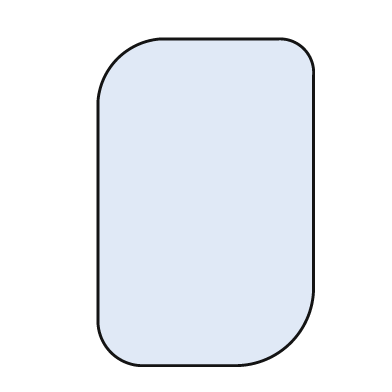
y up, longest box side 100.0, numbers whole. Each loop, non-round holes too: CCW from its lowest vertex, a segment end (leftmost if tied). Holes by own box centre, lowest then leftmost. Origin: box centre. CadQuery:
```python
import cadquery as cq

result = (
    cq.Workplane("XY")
    .moveTo(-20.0, -50.0)
    .lineTo(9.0, -50.0)
    .threePointArc((26.0, -43.0), (33.0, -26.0))
    .lineTo(33.0, 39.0)
    .threePointArc((30.0, 47.0), (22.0, 50.0))
    .lineTo(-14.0, 50.0)
    .threePointArc((-27.0, 44.0), (-33.0, 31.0))
    .lineTo(-33.0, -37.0)
    .threePointArc((-29.0, -46.0), (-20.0, -50.0))
    .close()
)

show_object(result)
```